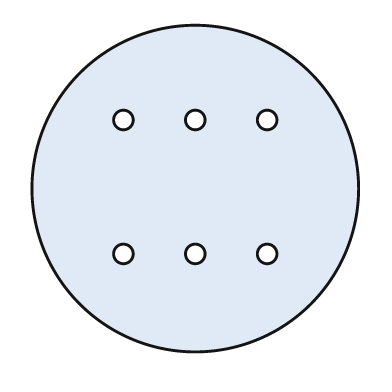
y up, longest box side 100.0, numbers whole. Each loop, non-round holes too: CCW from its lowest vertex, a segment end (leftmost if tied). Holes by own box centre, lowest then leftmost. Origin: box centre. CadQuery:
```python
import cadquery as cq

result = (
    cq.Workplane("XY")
    .moveTo(0.0, 0.0)
    .circle(50.0)
    .moveTo(-22.0, -20.0)
    .circle(3.0)
    .moveTo(0.0, -20.0)
    .circle(3.0)
    .moveTo(22.0, -20.0)
    .circle(3.0)
    .moveTo(-22.0, 21.0)
    .circle(3.0)
    .moveTo(0.0, 21.0)
    .circle(3.0)
    .moveTo(22.0, 21.0)
    .circle(3.0)
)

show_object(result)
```